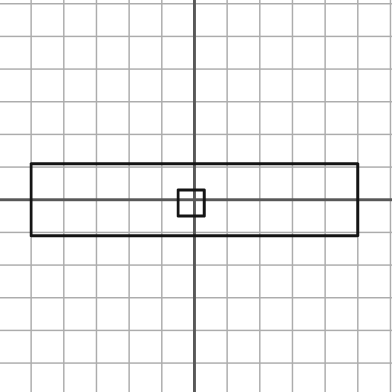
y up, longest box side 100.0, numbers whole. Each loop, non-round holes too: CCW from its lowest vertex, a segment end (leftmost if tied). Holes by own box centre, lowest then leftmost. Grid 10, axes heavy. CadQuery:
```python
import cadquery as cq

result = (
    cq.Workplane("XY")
    .moveTo(-50.0, -11.0)
    .lineTo(50.0, -11.0)
    .lineTo(50.0, 11.0)
    .lineTo(-50.0, 11.0)
    .close()
    .moveTo(-5.0, -5.0)
    .lineTo(3.0, -5.0)
    .lineTo(3.0, 3.0)
    .lineTo(-5.0, 3.0)
    .close()
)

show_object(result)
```